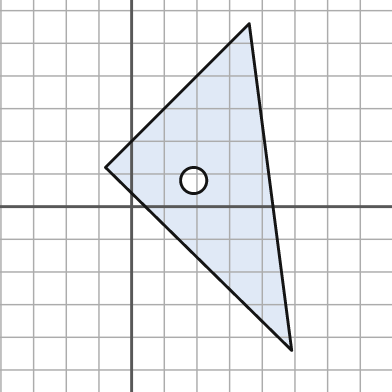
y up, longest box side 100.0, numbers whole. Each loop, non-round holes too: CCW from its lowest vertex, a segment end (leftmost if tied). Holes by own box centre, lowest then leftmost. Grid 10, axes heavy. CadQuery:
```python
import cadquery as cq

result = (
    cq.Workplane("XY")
    .moveTo(49.0, -44.0)
    .lineTo(36.0, 56.0)
    .lineTo(-8.0, 12.0)
    .close()
    .moveTo(19.0, 8.0)
    .circle(4.0)
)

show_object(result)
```